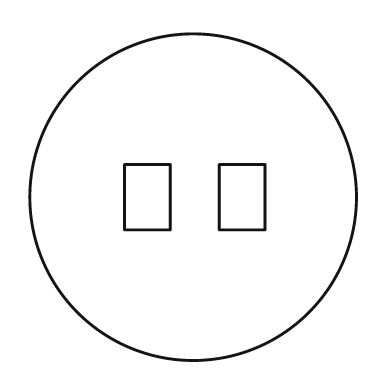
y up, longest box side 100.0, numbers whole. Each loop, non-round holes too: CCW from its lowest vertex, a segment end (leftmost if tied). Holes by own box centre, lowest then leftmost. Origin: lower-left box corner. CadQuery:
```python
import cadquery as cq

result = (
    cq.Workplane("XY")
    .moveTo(50.0, 50.0)
    .circle(50.0)
    .moveTo(29.0, 40.0)
    .lineTo(43.0, 40.0)
    .lineTo(43.0, 60.0)
    .lineTo(29.0, 60.0)
    .close()
    .moveTo(58.0, 40.0)
    .lineTo(72.0, 40.0)
    .lineTo(72.0, 60.0)
    .lineTo(58.0, 60.0)
    .close()
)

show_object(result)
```